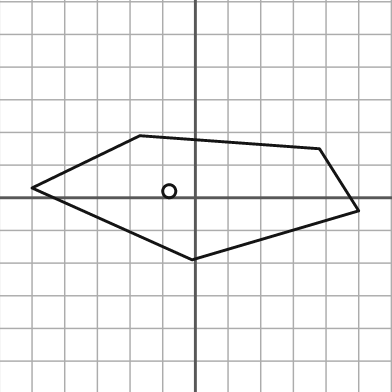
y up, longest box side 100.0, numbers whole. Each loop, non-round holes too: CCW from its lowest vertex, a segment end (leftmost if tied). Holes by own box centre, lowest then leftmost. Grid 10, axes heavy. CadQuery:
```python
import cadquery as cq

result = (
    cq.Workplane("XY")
    .moveTo(-1.0, -19.0)
    .lineTo(50.0, -4.0)
    .lineTo(38.0, 15.0)
    .lineTo(-17.0, 19.0)
    .lineTo(-50.0, 3.0)
    .close()
    .moveTo(-8.0, 2.0)
    .circle(2.0)
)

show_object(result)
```